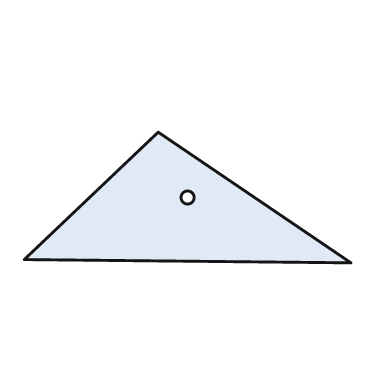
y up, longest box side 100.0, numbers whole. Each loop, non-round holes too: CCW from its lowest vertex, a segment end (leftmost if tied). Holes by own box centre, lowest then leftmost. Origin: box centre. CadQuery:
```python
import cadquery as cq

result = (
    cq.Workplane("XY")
    .moveTo(50.0, -20.0)
    .lineTo(-9.0, 20.0)
    .lineTo(-50.0, -19.0)
    .close()
    .moveTo(0.0, 0.0)
    .circle(2.0)
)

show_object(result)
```